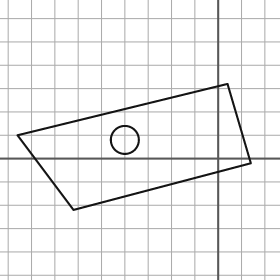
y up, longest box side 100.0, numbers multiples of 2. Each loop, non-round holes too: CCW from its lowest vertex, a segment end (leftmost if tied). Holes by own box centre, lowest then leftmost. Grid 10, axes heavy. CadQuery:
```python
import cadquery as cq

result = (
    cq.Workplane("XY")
    .moveTo(-62.0, -22.0)
    .lineTo(14.0, -2.0)
    .lineTo(4.0, 32.0)
    .lineTo(-86.0, 10.0)
    .close()
    .moveTo(-40.0, 8.0)
    .circle(6.0)
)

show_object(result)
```